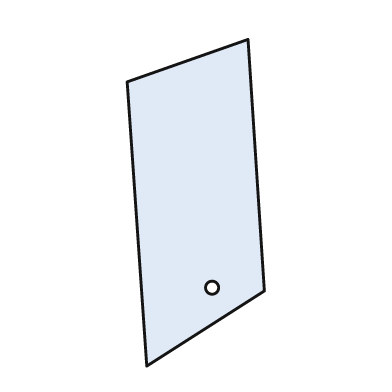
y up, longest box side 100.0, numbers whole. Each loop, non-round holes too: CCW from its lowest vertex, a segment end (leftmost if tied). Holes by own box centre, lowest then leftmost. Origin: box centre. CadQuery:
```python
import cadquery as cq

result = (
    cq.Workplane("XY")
    .moveTo(-15.0, -50.0)
    .lineTo(21.0, -27.0)
    .lineTo(16.0, 50.0)
    .lineTo(-21.0, 37.0)
    .close()
    .moveTo(5.0, -26.0)
    .circle(2.0)
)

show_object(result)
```